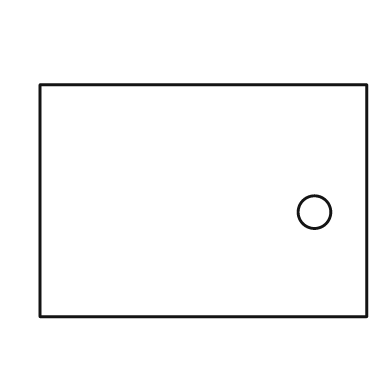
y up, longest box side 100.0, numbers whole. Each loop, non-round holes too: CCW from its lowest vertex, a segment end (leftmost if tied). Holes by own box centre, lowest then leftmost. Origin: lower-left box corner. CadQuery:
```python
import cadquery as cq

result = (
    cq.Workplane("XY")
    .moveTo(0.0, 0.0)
    .lineTo(100.0, 0.0)
    .lineTo(100.0, 71.0)
    .lineTo(0.0, 71.0)
    .close()
    .moveTo(84.0, 32.0)
    .circle(5.0)
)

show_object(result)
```